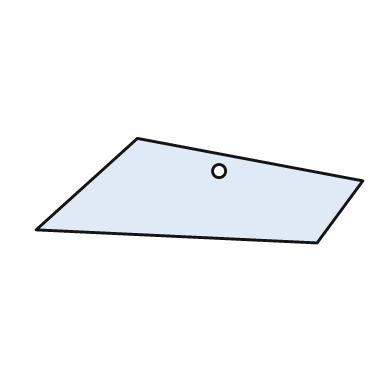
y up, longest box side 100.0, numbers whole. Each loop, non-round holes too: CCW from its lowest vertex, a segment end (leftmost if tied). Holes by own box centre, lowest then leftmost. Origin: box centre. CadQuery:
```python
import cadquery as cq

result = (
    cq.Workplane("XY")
    .moveTo(36.0, -16.0)
    .lineTo(50.0, 3.0)
    .lineTo(-19.0, 16.0)
    .lineTo(-50.0, -12.0)
    .close()
    .moveTo(6.0, 6.0)
    .circle(2.0)
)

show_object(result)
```